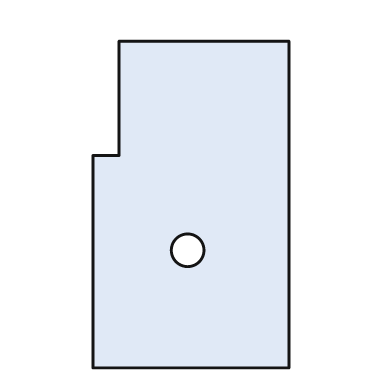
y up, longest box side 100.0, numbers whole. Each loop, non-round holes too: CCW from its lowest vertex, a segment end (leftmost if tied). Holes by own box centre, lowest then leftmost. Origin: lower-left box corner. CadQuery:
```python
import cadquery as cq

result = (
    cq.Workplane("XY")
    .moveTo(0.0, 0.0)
    .lineTo(60.0, 0.0)
    .lineTo(60.0, 100.0)
    .lineTo(8.0, 100.0)
    .lineTo(8.0, 65.0)
    .lineTo(0.0, 65.0)
    .close()
    .moveTo(29.0, 36.0)
    .circle(5.0)
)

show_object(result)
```